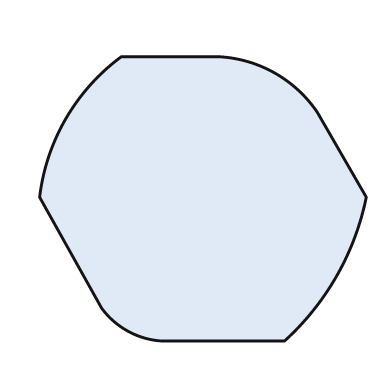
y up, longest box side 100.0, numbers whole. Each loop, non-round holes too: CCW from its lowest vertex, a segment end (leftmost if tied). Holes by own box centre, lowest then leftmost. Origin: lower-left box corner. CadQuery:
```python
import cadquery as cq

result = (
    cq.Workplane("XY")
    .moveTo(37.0, 0.0)
    .lineTo(75.0, 0.0)
    .threePointArc((91.0, 20.0), (100.0, 44.0))
    .lineTo(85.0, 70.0)
    .threePointArc((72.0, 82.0), (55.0, 87.0))
    .lineTo(25.0, 87.0)
    .threePointArc((8.0, 68.0), (0.0, 44.0))
    .lineTo(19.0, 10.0)
    .threePointArc((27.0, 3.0), (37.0, 0.0))
    .close()
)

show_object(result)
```